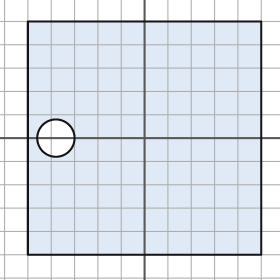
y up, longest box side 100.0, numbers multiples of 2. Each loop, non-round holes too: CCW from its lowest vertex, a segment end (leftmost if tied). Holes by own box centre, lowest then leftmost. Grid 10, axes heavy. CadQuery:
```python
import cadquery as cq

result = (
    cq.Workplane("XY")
    .moveTo(-50.0, -50.0)
    .lineTo(50.0, -50.0)
    .lineTo(50.0, 50.0)
    .lineTo(-50.0, 50.0)
    .close()
    .moveTo(-38.0, 0.0)
    .circle(8.0)
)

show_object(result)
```